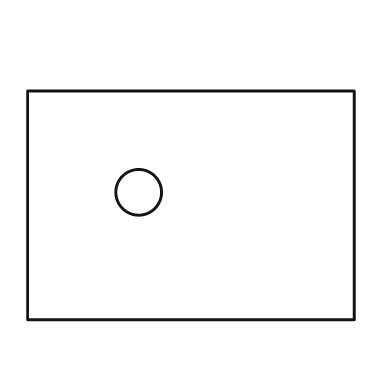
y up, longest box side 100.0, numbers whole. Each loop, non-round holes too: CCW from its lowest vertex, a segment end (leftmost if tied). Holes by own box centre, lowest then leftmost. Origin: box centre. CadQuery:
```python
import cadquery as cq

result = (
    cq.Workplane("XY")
    .moveTo(-50.0, -35.0)
    .lineTo(50.0, -35.0)
    .lineTo(50.0, 35.0)
    .lineTo(-50.0, 35.0)
    .close()
    .moveTo(-16.0, 4.0)
    .circle(7.0)
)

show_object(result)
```